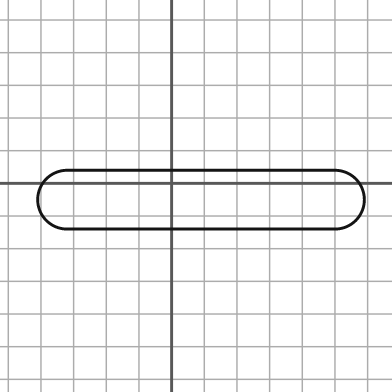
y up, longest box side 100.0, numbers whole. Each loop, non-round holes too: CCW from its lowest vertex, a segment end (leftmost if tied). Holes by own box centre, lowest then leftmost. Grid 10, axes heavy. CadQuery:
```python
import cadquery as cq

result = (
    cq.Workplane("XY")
    .moveTo(-32.0, -14.0)
    .lineTo(50.0, -14.0)
    .threePointArc((59.0, -5.0), (50.0, 4.0))
    .lineTo(-32.0, 4.0)
    .threePointArc((-41.0, -5.0), (-32.0, -14.0))
    .close()
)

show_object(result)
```